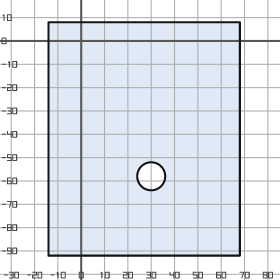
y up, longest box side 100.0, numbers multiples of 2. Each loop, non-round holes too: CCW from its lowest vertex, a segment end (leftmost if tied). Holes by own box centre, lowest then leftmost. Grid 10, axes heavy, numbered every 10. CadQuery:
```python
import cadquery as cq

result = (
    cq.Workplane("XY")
    .moveTo(-14.0, -92.0)
    .lineTo(68.0, -92.0)
    .lineTo(68.0, 8.0)
    .lineTo(-14.0, 8.0)
    .close()
    .moveTo(30.0, -58.0)
    .circle(6.0)
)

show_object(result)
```